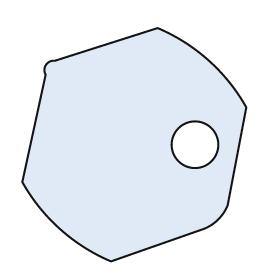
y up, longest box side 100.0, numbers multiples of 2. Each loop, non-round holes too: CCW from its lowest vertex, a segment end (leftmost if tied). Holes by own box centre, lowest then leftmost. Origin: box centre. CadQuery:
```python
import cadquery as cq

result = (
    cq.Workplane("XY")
    .moveTo(-10.0, -50.0)
    .lineTo(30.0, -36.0)
    .threePointArc((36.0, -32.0), (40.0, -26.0))
    .lineTo(48.0, 16.0)
    .threePointArc((32.0, 36.0), (10.0, 50.0))
    .lineTo(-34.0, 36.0)
    .threePointArc((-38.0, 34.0), (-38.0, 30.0))
    .lineTo(-48.0, -16.0)
    .threePointArc((-32.0, -36.0), (-10.0, -50.0))
    .close()
    .moveTo(26.0, 0.0)
    .circle(10.0)
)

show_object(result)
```